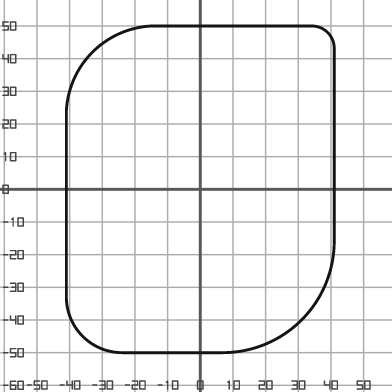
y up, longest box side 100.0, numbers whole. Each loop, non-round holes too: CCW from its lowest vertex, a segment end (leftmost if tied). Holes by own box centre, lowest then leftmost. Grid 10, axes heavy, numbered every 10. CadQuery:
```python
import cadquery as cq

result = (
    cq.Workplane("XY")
    .moveTo(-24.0, -50.0)
    .lineTo(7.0, -50.0)
    .threePointArc((31.0, -40.0), (41.0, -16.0))
    .lineTo(41.0, 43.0)
    .threePointArc((39.0, 48.0), (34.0, 50.0))
    .lineTo(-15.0, 50.0)
    .threePointArc((-33.0, 42.0), (-41.0, 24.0))
    .lineTo(-41.0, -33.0)
    .threePointArc((-36.0, -45.0), (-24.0, -50.0))
    .close()
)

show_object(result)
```